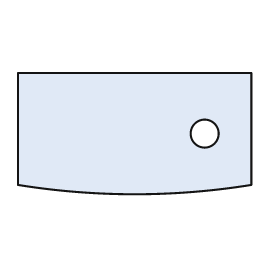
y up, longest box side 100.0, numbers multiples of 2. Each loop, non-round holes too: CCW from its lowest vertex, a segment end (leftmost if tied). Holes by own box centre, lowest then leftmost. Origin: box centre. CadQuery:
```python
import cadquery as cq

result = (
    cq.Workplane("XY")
    .moveTo(-50.0, -22.0)
    .threePointArc((0.0, -26.0), (50.0, -22.0))
    .lineTo(50.0, 26.0)
    .lineTo(-50.0, 26.0)
    .close()
    .moveTo(30.0, 0.0)
    .circle(6.0)
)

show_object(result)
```